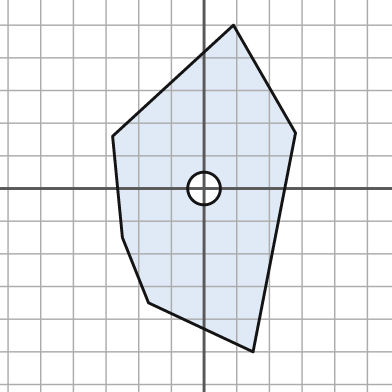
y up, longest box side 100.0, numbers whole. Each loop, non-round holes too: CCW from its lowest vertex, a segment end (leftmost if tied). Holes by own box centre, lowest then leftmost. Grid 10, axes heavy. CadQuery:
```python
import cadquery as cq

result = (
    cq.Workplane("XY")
    .moveTo(15.0, -50.0)
    .lineTo(28.0, 17.0)
    .lineTo(9.0, 50.0)
    .lineTo(-28.0, 16.0)
    .lineTo(-25.0, -15.0)
    .lineTo(-17.0, -35.0)
    .close()
    .moveTo(0.0, 0.0)
    .circle(5.0)
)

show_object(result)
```